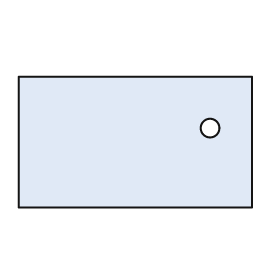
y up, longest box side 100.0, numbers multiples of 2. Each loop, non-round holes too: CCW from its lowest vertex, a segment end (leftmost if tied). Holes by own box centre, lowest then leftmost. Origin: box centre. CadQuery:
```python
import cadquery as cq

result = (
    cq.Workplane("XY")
    .moveTo(-50.0, -28.0)
    .lineTo(50.0, -28.0)
    .lineTo(50.0, 28.0)
    .lineTo(-50.0, 28.0)
    .close()
    .moveTo(32.0, 6.0)
    .circle(4.0)
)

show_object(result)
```